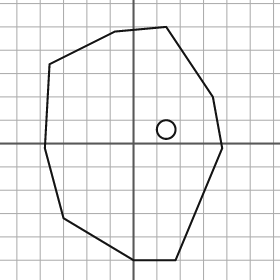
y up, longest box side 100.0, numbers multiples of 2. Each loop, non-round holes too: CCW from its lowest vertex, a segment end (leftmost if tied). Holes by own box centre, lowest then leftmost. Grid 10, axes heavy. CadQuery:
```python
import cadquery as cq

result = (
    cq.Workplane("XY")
    .moveTo(0.0, -50.0)
    .lineTo(18.0, -50.0)
    .lineTo(38.0, -2.0)
    .lineTo(34.0, 20.0)
    .lineTo(14.0, 50.0)
    .lineTo(-8.0, 48.0)
    .lineTo(-36.0, 34.0)
    .lineTo(-38.0, -2.0)
    .lineTo(-30.0, -32.0)
    .close()
    .moveTo(14.0, 6.0)
    .circle(4.0)
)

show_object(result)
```